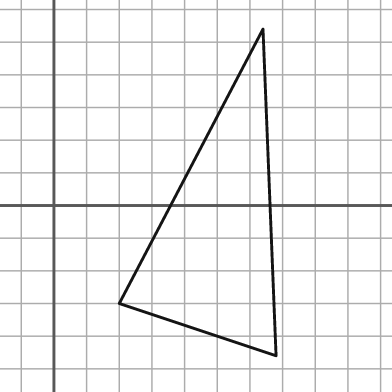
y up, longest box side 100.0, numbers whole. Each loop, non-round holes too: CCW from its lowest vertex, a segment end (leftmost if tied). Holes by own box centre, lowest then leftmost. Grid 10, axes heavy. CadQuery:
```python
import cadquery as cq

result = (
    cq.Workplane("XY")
    .moveTo(68.0, -46.0)
    .lineTo(64.0, 54.0)
    .lineTo(20.0, -30.0)
    .close()
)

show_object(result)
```